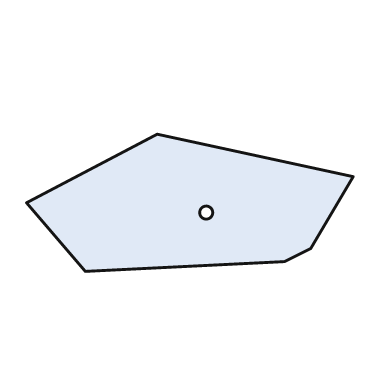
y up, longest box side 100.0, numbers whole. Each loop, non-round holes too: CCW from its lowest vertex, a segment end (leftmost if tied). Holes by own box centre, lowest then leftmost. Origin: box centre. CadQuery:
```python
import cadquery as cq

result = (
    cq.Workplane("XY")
    .moveTo(-32.0, -21.0)
    .lineTo(29.0, -18.0)
    .lineTo(37.0, -14.0)
    .lineTo(50.0, 8.0)
    .lineTo(-10.0, 21.0)
    .lineTo(-50.0, 0.0)
    .close()
    .moveTo(5.0, -3.0)
    .circle(2.0)
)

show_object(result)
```